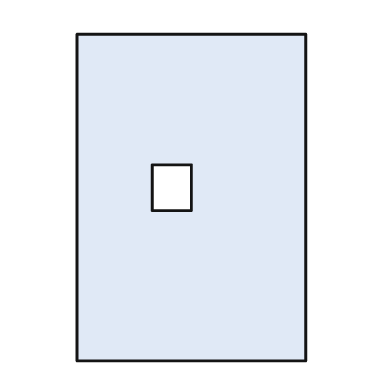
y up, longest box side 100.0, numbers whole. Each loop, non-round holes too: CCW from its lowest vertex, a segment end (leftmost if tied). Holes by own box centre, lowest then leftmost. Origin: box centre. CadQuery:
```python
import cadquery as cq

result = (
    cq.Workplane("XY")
    .moveTo(-35.0, -50.0)
    .lineTo(35.0, -50.0)
    .lineTo(35.0, 50.0)
    .lineTo(-35.0, 50.0)
    .close()
    .moveTo(-12.0, -4.0)
    .lineTo(0.0, -4.0)
    .lineTo(0.0, 10.0)
    .lineTo(-12.0, 10.0)
    .close()
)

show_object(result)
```